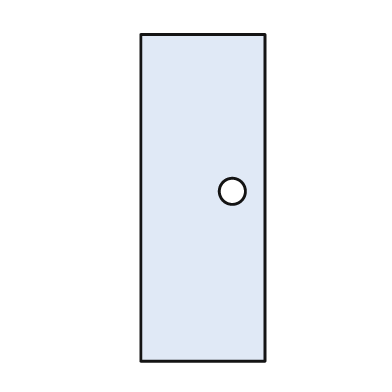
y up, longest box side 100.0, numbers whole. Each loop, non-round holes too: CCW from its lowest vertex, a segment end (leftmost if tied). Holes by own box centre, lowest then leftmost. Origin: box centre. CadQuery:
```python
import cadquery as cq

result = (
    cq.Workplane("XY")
    .moveTo(-19.0, -50.0)
    .lineTo(19.0, -50.0)
    .lineTo(19.0, 50.0)
    .lineTo(-19.0, 50.0)
    .close()
    .moveTo(9.0, 2.0)
    .circle(4.0)
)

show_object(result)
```